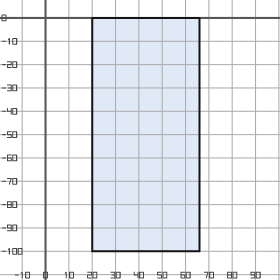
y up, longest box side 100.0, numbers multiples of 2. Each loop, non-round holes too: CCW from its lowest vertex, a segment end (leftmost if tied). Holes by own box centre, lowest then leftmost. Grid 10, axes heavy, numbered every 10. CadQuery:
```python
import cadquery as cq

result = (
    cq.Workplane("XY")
    .moveTo(20.0, -100.0)
    .lineTo(66.0, -100.0)
    .lineTo(66.0, 0.0)
    .lineTo(20.0, 0.0)
    .close()
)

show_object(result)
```